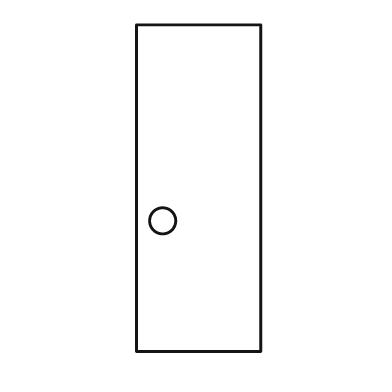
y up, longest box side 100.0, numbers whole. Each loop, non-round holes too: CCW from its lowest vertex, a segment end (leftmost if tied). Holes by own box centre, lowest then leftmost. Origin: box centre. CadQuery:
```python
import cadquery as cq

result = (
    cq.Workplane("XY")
    .moveTo(-19.0, -50.0)
    .lineTo(19.0, -50.0)
    .lineTo(19.0, 50.0)
    .lineTo(-19.0, 50.0)
    .close()
    .moveTo(-11.0, -10.0)
    .circle(4.0)
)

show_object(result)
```